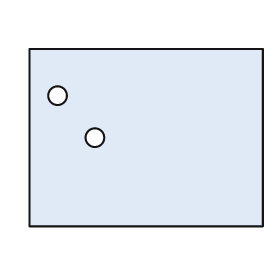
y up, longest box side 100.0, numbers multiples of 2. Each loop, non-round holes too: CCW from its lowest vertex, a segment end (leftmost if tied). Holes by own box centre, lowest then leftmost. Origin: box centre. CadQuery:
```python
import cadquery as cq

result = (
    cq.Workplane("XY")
    .moveTo(-50.0, -38.0)
    .lineTo(50.0, -38.0)
    .lineTo(50.0, 38.0)
    .lineTo(-50.0, 38.0)
    .close()
    .moveTo(-22.0, 0.0)
    .circle(4.0)
    .moveTo(-38.0, 18.0)
    .circle(4.0)
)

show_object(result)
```